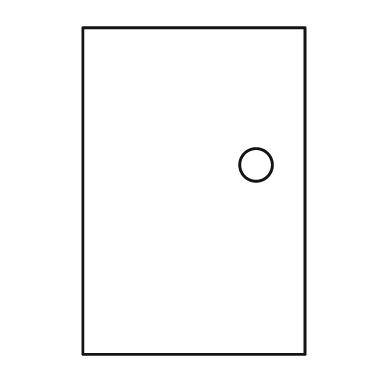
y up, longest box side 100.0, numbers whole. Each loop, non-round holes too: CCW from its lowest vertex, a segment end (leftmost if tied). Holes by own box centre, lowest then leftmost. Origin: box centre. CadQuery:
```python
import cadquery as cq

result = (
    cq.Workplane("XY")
    .moveTo(-34.0, -50.0)
    .lineTo(34.0, -50.0)
    .lineTo(34.0, 50.0)
    .lineTo(-34.0, 50.0)
    .close()
    .moveTo(19.0, 8.0)
    .circle(5.0)
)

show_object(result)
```